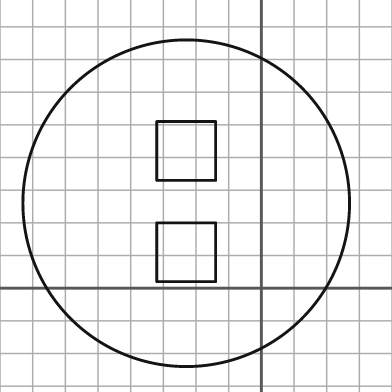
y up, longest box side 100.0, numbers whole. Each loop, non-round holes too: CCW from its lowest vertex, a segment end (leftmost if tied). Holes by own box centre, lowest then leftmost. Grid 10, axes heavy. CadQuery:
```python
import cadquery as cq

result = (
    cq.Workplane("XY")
    .moveTo(-23.0, 26.0)
    .circle(50.0)
    .moveTo(-32.0, 2.0)
    .lineTo(-14.0, 2.0)
    .lineTo(-14.0, 20.0)
    .lineTo(-32.0, 20.0)
    .close()
    .moveTo(-32.0, 33.0)
    .lineTo(-14.0, 33.0)
    .lineTo(-14.0, 51.0)
    .lineTo(-32.0, 51.0)
    .close()
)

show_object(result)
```